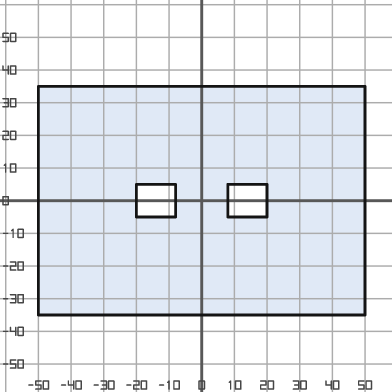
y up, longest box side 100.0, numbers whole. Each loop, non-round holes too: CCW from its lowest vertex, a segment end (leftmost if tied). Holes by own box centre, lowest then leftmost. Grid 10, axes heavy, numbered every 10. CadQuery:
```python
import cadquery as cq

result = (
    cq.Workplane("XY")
    .moveTo(-50.0, -35.0)
    .lineTo(50.0, -35.0)
    .lineTo(50.0, 35.0)
    .lineTo(-50.0, 35.0)
    .close()
    .moveTo(-20.0, -5.0)
    .lineTo(-8.0, -5.0)
    .lineTo(-8.0, 5.0)
    .lineTo(-20.0, 5.0)
    .close()
    .moveTo(8.0, -5.0)
    .lineTo(20.0, -5.0)
    .lineTo(20.0, 5.0)
    .lineTo(8.0, 5.0)
    .close()
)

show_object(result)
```